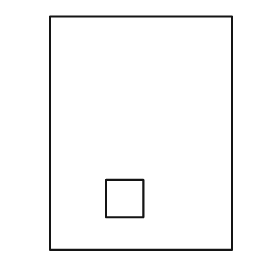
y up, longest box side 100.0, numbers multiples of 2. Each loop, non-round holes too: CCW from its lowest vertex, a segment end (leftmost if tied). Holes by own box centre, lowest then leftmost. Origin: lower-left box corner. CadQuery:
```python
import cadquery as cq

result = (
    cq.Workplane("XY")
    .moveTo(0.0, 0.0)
    .lineTo(78.0, 0.0)
    .lineTo(78.0, 100.0)
    .lineTo(0.0, 100.0)
    .close()
    .moveTo(24.0, 14.0)
    .lineTo(40.0, 14.0)
    .lineTo(40.0, 30.0)
    .lineTo(24.0, 30.0)
    .close()
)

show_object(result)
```